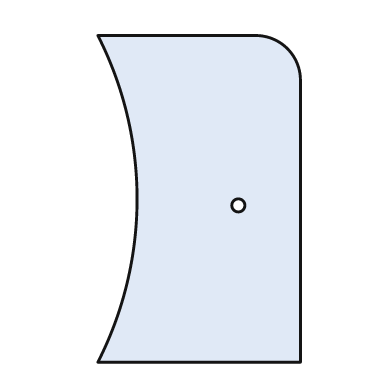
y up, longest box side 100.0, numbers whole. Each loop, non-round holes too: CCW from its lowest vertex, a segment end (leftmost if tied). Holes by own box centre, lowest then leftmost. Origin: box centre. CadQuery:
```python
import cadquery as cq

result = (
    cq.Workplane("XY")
    .moveTo(-31.0, -50.0)
    .lineTo(31.0, -50.0)
    .lineTo(31.0, 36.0)
    .threePointArc((27.0, 46.0), (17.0, 50.0))
    .lineTo(-31.0, 50.0)
    .threePointArc((-19.0, 0.0), (-31.0, -50.0))
    .close()
    .moveTo(12.0, -2.0)
    .circle(2.0)
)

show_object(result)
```